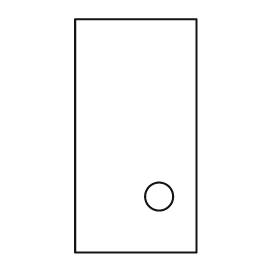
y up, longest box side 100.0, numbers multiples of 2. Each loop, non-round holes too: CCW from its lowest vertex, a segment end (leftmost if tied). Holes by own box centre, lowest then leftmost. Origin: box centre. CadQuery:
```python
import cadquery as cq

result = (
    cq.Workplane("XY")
    .moveTo(-26.0, -50.0)
    .lineTo(26.0, -50.0)
    .lineTo(26.0, 50.0)
    .lineTo(-26.0, 50.0)
    .close()
    .moveTo(10.0, -26.0)
    .circle(6.0)
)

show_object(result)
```